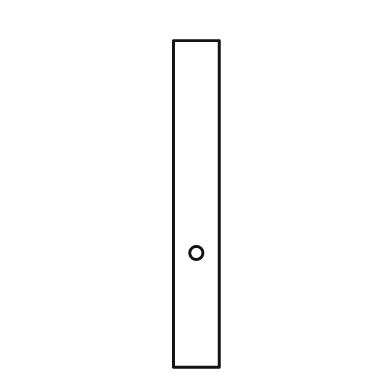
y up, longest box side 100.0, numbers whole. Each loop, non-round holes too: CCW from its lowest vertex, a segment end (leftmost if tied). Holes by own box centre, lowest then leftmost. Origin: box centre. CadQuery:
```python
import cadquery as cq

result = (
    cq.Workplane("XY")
    .moveTo(-7.0, -50.0)
    .lineTo(7.0, -50.0)
    .lineTo(7.0, 50.0)
    .lineTo(-7.0, 50.0)
    .close()
    .moveTo(0.0, -15.0)
    .circle(2.0)
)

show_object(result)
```